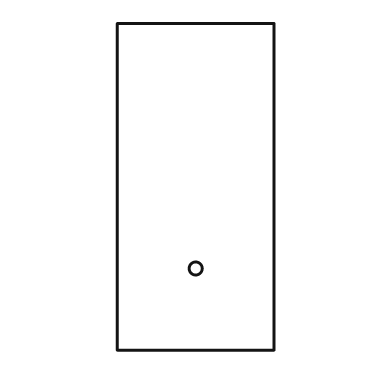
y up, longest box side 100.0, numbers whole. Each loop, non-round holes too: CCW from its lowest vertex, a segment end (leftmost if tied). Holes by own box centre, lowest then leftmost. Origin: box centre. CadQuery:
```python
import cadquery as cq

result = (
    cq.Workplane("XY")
    .moveTo(-24.0, -50.0)
    .lineTo(24.0, -50.0)
    .lineTo(24.0, 50.0)
    .lineTo(-24.0, 50.0)
    .close()
    .moveTo(0.0, -25.0)
    .circle(2.0)
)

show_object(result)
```